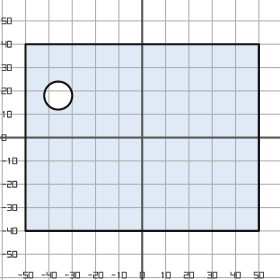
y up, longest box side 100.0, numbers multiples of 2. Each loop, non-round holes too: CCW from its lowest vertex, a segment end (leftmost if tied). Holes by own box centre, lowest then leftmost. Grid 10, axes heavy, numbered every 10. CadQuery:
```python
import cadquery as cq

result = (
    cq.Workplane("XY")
    .moveTo(-50.0, -40.0)
    .lineTo(50.0, -40.0)
    .lineTo(50.0, 40.0)
    .lineTo(-50.0, 40.0)
    .close()
    .moveTo(-36.0, 18.0)
    .circle(6.0)
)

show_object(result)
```